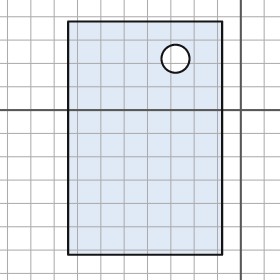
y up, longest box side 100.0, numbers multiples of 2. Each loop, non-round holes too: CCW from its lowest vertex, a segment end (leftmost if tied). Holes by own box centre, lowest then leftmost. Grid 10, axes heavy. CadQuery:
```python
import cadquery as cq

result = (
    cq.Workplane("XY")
    .moveTo(-74.0, -62.0)
    .lineTo(-8.0, -62.0)
    .lineTo(-8.0, 38.0)
    .lineTo(-74.0, 38.0)
    .close()
    .moveTo(-28.0, 22.0)
    .circle(6.0)
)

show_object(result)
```